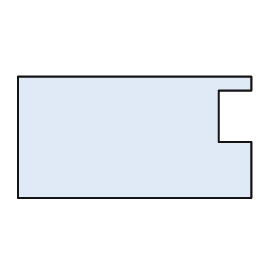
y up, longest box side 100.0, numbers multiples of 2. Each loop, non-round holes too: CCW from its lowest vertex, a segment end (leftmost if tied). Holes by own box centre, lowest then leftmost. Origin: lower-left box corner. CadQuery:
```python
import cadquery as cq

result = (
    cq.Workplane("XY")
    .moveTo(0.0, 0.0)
    .lineTo(100.0, 0.0)
    .lineTo(100.0, 24.0)
    .lineTo(86.0, 24.0)
    .lineTo(86.0, 46.0)
    .lineTo(100.0, 46.0)
    .lineTo(100.0, 52.0)
    .lineTo(0.0, 52.0)
    .close()
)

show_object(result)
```